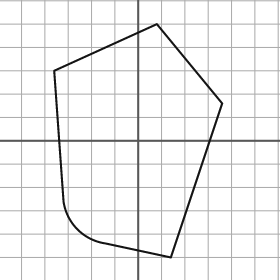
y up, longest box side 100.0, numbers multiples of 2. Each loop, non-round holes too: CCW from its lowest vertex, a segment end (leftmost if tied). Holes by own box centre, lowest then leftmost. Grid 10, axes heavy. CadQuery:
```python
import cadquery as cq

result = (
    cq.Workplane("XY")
    .moveTo(14.0, -50.0)
    .lineTo(36.0, 16.0)
    .lineTo(8.0, 50.0)
    .lineTo(-36.0, 30.0)
    .lineTo(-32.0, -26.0)
    .threePointArc((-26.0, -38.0), (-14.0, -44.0))
    .close()
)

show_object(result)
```